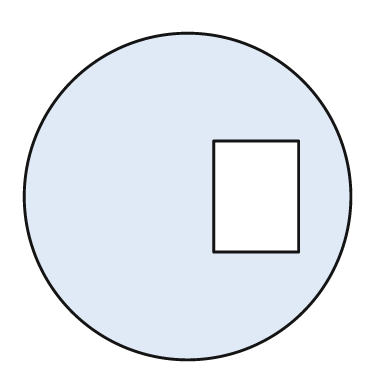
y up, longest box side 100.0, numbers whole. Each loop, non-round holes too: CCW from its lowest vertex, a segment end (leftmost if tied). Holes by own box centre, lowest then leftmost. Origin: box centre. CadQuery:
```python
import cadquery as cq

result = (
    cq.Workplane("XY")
    .moveTo(0.0, 0.0)
    .circle(50.0)
    .moveTo(8.0, -17.0)
    .lineTo(34.0, -17.0)
    .lineTo(34.0, 17.0)
    .lineTo(8.0, 17.0)
    .close()
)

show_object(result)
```